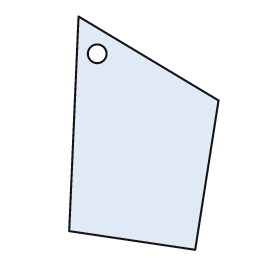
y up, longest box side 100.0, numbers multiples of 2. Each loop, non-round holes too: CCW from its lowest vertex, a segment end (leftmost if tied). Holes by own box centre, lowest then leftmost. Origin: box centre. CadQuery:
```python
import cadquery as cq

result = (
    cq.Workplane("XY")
    .moveTo(22.0, -50.0)
    .lineTo(32.0, 14.0)
    .lineTo(-28.0, 50.0)
    .lineTo(-32.0, -42.0)
    .close()
    .moveTo(-20.0, 34.0)
    .circle(4.0)
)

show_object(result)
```